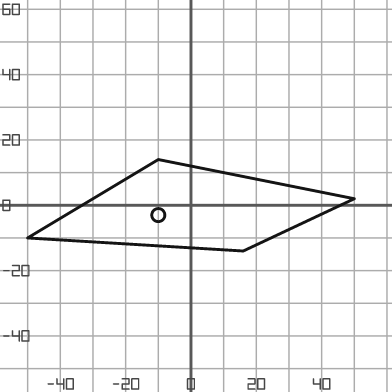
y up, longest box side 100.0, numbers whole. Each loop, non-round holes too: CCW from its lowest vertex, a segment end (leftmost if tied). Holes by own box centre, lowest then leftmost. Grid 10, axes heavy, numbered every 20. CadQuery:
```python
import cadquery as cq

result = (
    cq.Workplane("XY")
    .moveTo(16.0, -14.0)
    .lineTo(50.0, 2.0)
    .lineTo(-10.0, 14.0)
    .lineTo(-50.0, -10.0)
    .close()
    .moveTo(-10.0, -3.0)
    .circle(2.0)
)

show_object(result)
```